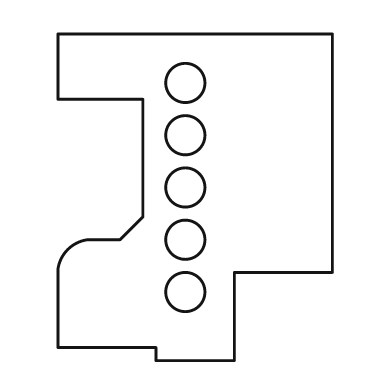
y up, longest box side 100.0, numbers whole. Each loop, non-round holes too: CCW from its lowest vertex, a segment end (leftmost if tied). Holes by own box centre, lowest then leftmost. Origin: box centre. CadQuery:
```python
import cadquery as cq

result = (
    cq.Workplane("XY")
    .moveTo(-12.0, -50.0)
    .lineTo(12.0, -50.0)
    .lineTo(12.0, -23.0)
    .lineTo(42.0, -23.0)
    .lineTo(42.0, 50.0)
    .lineTo(-42.0, 50.0)
    .lineTo(-42.0, 30.0)
    .lineTo(-16.0, 30.0)
    .lineTo(-16.0, -6.0)
    .lineTo(-23.0, -13.0)
    .lineTo(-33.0, -13.0)
    .threePointArc((-39.0, -16.0), (-42.0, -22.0))
    .lineTo(-42.0, -46.0)
    .lineTo(-12.0, -46.0)
    .close()
    .moveTo(-3.0, -29.0)
    .circle(6.0)
    .moveTo(-3.0, -13.0)
    .circle(6.0)
    .moveTo(-3.0, 3.0)
    .circle(6.0)
    .moveTo(-3.0, 19.0)
    .circle(6.0)
    .moveTo(-3.0, 35.0)
    .circle(6.0)
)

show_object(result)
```